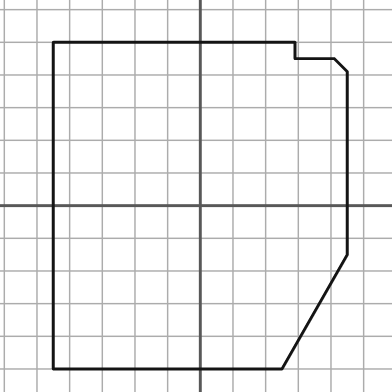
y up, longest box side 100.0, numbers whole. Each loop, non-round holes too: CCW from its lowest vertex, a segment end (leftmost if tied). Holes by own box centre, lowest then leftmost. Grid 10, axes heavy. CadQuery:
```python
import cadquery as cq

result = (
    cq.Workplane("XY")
    .moveTo(-45.0, -50.0)
    .lineTo(25.0, -50.0)
    .lineTo(45.0, -15.0)
    .lineTo(45.0, 41.0)
    .lineTo(41.0, 45.0)
    .lineTo(29.0, 45.0)
    .lineTo(29.0, 50.0)
    .lineTo(-45.0, 50.0)
    .close()
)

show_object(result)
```